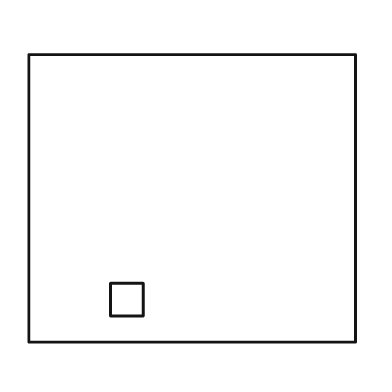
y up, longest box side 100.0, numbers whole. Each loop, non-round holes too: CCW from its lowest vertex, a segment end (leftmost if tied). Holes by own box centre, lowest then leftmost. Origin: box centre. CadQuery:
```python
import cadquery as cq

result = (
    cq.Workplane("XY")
    .moveTo(-50.0, -44.0)
    .lineTo(50.0, -44.0)
    .lineTo(50.0, 44.0)
    .lineTo(-50.0, 44.0)
    .close()
    .moveTo(-25.0, -36.0)
    .lineTo(-15.0, -36.0)
    .lineTo(-15.0, -26.0)
    .lineTo(-25.0, -26.0)
    .close()
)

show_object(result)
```